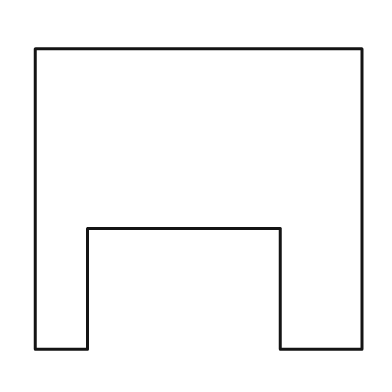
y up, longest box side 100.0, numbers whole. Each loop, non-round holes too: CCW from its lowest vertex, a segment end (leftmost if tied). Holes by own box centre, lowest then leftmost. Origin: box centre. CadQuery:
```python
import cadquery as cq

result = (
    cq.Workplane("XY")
    .moveTo(-50.0, -46.0)
    .lineTo(-34.0, -46.0)
    .lineTo(-34.0, -9.0)
    .lineTo(25.0, -9.0)
    .lineTo(25.0, -46.0)
    .lineTo(50.0, -46.0)
    .lineTo(50.0, 46.0)
    .lineTo(-50.0, 46.0)
    .close()
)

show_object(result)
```